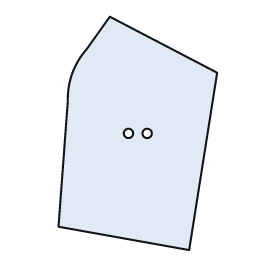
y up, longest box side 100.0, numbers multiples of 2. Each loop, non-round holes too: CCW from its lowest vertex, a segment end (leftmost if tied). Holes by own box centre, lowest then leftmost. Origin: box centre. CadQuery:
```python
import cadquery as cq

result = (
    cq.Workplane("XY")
    .moveTo(22.0, -50.0)
    .lineTo(34.0, 26.0)
    .lineTo(-12.0, 50.0)
    .lineTo(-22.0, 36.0)
    .threePointArc((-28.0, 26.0), (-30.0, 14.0))
    .lineTo(-34.0, -40.0)
    .close()
    .moveTo(-4.0, 0.0)
    .circle(2.0)
    .moveTo(4.0, 0.0)
    .circle(2.0)
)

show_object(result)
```